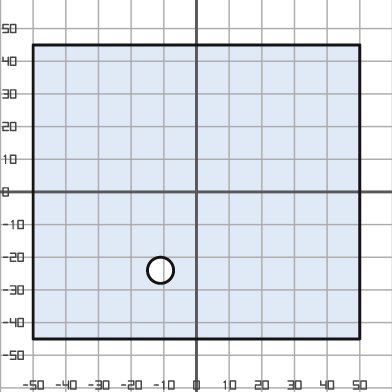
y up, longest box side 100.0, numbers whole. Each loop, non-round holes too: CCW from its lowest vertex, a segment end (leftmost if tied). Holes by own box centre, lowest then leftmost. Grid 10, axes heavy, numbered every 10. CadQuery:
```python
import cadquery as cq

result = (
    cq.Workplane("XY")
    .moveTo(-50.0, -45.0)
    .lineTo(50.0, -45.0)
    .lineTo(50.0, 45.0)
    .lineTo(-50.0, 45.0)
    .close()
    .moveTo(-11.0, -24.0)
    .circle(4.0)
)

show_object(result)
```